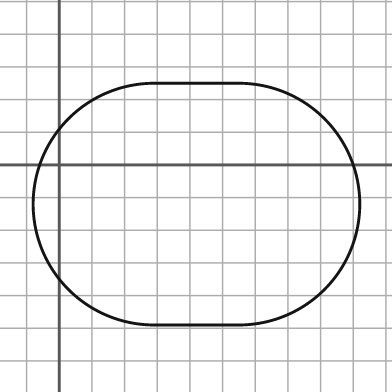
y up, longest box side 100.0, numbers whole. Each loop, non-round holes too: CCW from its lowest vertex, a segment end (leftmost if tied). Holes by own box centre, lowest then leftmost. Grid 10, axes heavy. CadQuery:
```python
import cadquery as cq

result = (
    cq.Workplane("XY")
    .moveTo(29.0, -49.0)
    .lineTo(55.0, -49.0)
    .threePointArc((92.0, -12.0), (55.0, 25.0))
    .lineTo(29.0, 25.0)
    .threePointArc((-8.0, -12.0), (29.0, -49.0))
    .close()
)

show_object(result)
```